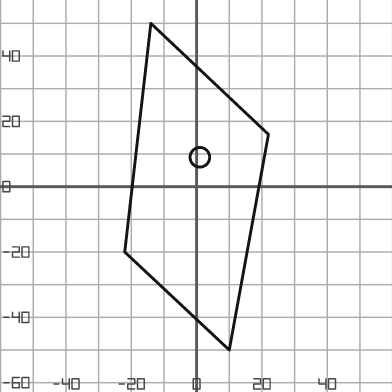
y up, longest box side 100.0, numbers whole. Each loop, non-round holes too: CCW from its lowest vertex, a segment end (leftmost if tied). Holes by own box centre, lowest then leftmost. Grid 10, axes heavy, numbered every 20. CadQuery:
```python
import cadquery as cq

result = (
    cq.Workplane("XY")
    .moveTo(10.0, -50.0)
    .lineTo(22.0, 16.0)
    .lineTo(-14.0, 50.0)
    .lineTo(-22.0, -20.0)
    .close()
    .moveTo(1.0, 9.0)
    .circle(3.0)
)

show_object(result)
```